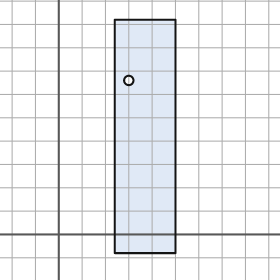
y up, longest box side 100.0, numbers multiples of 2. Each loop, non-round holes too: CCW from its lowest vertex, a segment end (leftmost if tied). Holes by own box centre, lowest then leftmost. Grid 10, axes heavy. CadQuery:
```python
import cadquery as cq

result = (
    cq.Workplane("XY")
    .moveTo(24.0, -8.0)
    .lineTo(50.0, -8.0)
    .lineTo(50.0, 92.0)
    .lineTo(24.0, 92.0)
    .close()
    .moveTo(30.0, 66.0)
    .circle(2.0)
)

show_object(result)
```